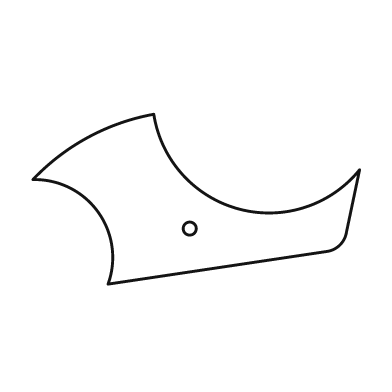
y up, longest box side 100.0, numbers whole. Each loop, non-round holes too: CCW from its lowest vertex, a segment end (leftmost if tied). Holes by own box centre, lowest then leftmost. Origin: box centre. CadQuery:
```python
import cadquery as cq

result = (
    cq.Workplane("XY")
    .moveTo(-27.0, -26.0)
    .lineTo(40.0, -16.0)
    .threePointArc((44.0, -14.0), (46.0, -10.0))
    .lineTo(50.0, 9.0)
    .threePointArc((13.0, -3.0), (-13.0, 26.0))
    .threePointArc((-33.0, 19.0), (-50.0, 6.0))
    .threePointArc((-30.0, -4.0), (-27.0, -26.0))
    .close()
    .moveTo(-2.0, -9.0)
    .circle(2.0)
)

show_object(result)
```